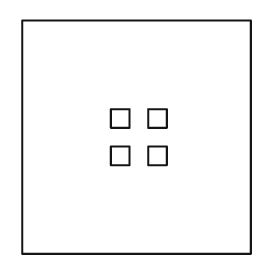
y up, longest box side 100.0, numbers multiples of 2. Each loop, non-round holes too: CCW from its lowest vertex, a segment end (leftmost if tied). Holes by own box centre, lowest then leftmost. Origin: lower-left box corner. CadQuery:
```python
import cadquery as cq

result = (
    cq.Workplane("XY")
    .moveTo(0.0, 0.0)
    .lineTo(98.0, 0.0)
    .lineTo(98.0, 100.0)
    .lineTo(0.0, 100.0)
    .close()
    .moveTo(38.0, 38.0)
    .lineTo(46.0, 38.0)
    .lineTo(46.0, 46.0)
    .lineTo(38.0, 46.0)
    .close()
    .moveTo(54.0, 38.0)
    .lineTo(62.0, 38.0)
    .lineTo(62.0, 46.0)
    .lineTo(54.0, 46.0)
    .close()
    .moveTo(38.0, 54.0)
    .lineTo(46.0, 54.0)
    .lineTo(46.0, 62.0)
    .lineTo(38.0, 62.0)
    .close()
    .moveTo(54.0, 54.0)
    .lineTo(62.0, 54.0)
    .lineTo(62.0, 62.0)
    .lineTo(54.0, 62.0)
    .close()
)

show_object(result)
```